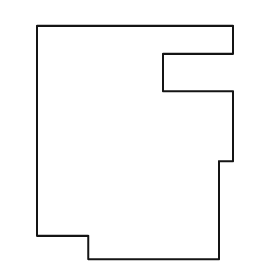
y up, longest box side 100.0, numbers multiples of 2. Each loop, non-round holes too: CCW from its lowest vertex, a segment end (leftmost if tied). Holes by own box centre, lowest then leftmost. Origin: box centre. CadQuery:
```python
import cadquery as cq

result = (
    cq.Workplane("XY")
    .moveTo(-20.0, -50.0)
    .lineTo(36.0, -50.0)
    .lineTo(36.0, -8.0)
    .lineTo(42.0, -8.0)
    .lineTo(42.0, 22.0)
    .lineTo(12.0, 22.0)
    .lineTo(12.0, 38.0)
    .lineTo(42.0, 38.0)
    .lineTo(42.0, 50.0)
    .lineTo(-42.0, 50.0)
    .lineTo(-42.0, -40.0)
    .lineTo(-20.0, -40.0)
    .close()
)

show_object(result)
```